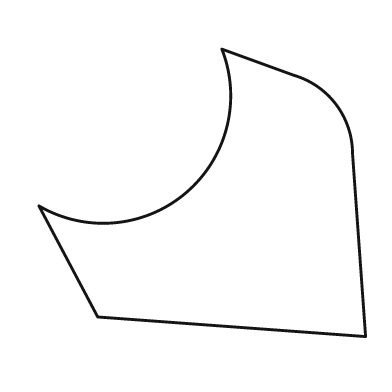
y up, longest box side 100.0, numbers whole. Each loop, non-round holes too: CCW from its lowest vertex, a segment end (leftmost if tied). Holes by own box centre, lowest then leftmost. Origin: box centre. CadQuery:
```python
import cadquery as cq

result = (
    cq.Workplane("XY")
    .moveTo(50.0, -44.0)
    .lineTo(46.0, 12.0)
    .threePointArc((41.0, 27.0), (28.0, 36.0))
    .lineTo(6.0, 44.0)
    .threePointArc((-5.0, 0.0), (-50.0, -4.0))
    .lineTo(-32.0, -38.0)
    .close()
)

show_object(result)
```